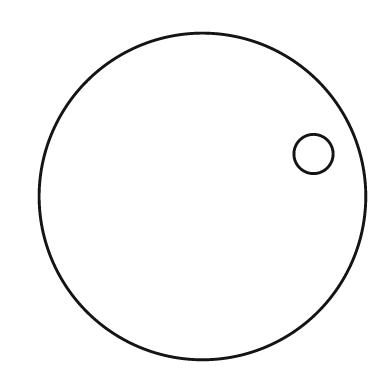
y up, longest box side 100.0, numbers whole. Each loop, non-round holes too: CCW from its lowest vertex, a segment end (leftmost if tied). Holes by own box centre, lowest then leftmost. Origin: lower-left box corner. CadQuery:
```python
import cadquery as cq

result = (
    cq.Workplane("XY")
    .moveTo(50.0, 50.0)
    .circle(50.0)
    .moveTo(84.0, 63.0)
    .circle(6.0)
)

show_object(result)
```